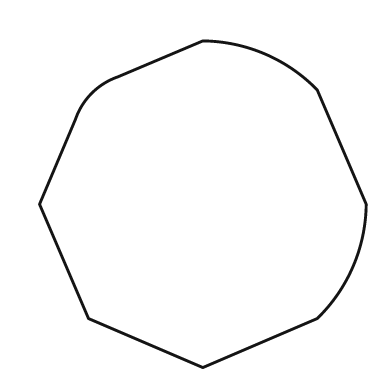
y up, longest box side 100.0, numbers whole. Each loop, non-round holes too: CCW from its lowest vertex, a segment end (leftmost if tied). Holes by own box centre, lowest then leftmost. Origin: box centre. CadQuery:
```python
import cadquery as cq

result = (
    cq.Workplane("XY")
    .moveTo(0.0, -50.0)
    .lineTo(35.0, -35.0)
    .threePointArc((46.0, -19.0), (50.0, 0.0))
    .lineTo(35.0, 35.0)
    .threePointArc((19.0, 46.0), (0.0, 50.0))
    .lineTo(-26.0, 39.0)
    .threePointArc((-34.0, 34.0), (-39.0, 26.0))
    .lineTo(-50.0, 0.0)
    .lineTo(-35.0, -35.0)
    .close()
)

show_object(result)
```